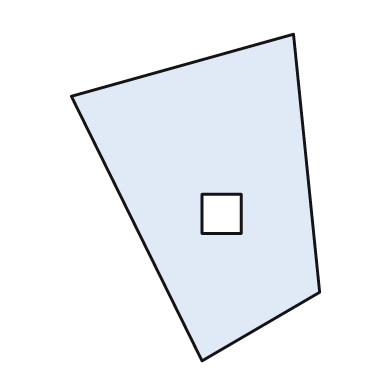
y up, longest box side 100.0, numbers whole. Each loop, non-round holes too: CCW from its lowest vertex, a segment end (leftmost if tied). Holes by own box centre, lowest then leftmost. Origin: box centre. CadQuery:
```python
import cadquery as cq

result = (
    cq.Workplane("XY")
    .moveTo(2.0, -50.0)
    .lineTo(38.0, -29.0)
    .lineTo(30.0, 50.0)
    .lineTo(-38.0, 31.0)
    .close()
    .moveTo(2.0, -11.0)
    .lineTo(14.0, -11.0)
    .lineTo(14.0, 1.0)
    .lineTo(2.0, 1.0)
    .close()
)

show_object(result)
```